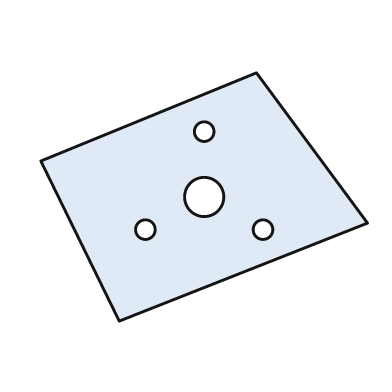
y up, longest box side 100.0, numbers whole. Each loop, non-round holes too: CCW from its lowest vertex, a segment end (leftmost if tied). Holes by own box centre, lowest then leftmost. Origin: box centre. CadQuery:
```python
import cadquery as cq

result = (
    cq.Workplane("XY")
    .moveTo(-26.0, -38.0)
    .lineTo(50.0, -8.0)
    .lineTo(16.0, 38.0)
    .lineTo(-50.0, 11.0)
    .close()
    .moveTo(-18.0, -10.0)
    .circle(3.0)
    .moveTo(18.0, -10.0)
    .circle(3.0)
    .moveTo(0.0, 0.0)
    .circle(6.0)
    .moveTo(0.0, 20.0)
    .circle(3.0)
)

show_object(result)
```